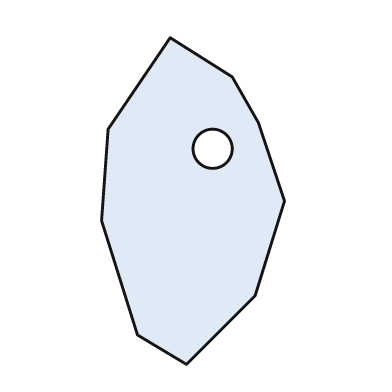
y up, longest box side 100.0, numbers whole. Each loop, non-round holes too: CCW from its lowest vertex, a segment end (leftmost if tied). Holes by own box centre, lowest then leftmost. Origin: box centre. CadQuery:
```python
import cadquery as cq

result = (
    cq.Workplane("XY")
    .moveTo(-2.0, -50.0)
    .lineTo(19.0, -29.0)
    .lineTo(28.0, 0.0)
    .lineTo(20.0, 24.0)
    .lineTo(12.0, 38.0)
    .lineTo(-7.0, 50.0)
    .lineTo(-26.0, 22.0)
    .lineTo(-28.0, -6.0)
    .lineTo(-17.0, -41.0)
    .close()
    .moveTo(6.0, 16.0)
    .circle(6.0)
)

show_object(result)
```